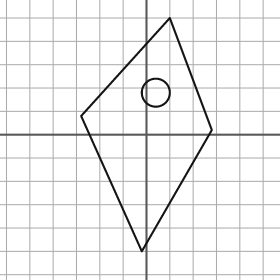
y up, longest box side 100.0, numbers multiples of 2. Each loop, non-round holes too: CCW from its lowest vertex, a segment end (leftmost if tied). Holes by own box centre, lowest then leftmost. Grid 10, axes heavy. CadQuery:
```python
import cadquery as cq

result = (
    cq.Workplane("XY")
    .moveTo(-2.0, -50.0)
    .lineTo(28.0, 2.0)
    .lineTo(10.0, 50.0)
    .lineTo(-28.0, 8.0)
    .close()
    .moveTo(4.0, 18.0)
    .circle(6.0)
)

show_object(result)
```